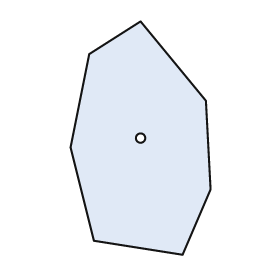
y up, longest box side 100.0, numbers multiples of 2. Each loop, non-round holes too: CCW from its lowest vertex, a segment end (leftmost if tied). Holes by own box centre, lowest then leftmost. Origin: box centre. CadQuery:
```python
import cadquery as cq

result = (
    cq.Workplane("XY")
    .moveTo(18.0, -50.0)
    .lineTo(30.0, -22.0)
    .lineTo(28.0, 16.0)
    .lineTo(0.0, 50.0)
    .lineTo(-22.0, 36.0)
    .lineTo(-30.0, -4.0)
    .lineTo(-20.0, -44.0)
    .close()
    .moveTo(0.0, 0.0)
    .circle(2.0)
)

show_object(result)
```